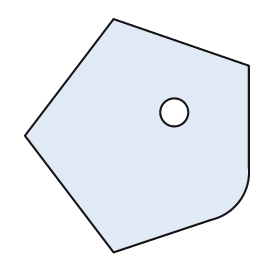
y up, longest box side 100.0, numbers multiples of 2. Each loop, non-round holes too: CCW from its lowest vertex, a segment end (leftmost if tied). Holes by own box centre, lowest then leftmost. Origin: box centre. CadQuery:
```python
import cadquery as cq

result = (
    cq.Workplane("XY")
    .moveTo(-10.0, -50.0)
    .lineTo(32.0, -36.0)
    .threePointArc((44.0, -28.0), (48.0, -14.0))
    .lineTo(48.0, 30.0)
    .lineTo(-10.0, 50.0)
    .lineTo(-48.0, 0.0)
    .close()
    .moveTo(16.0, 10.0)
    .circle(6.0)
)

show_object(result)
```